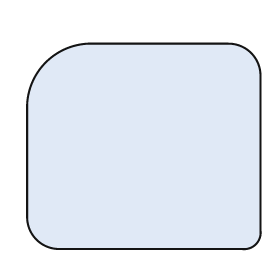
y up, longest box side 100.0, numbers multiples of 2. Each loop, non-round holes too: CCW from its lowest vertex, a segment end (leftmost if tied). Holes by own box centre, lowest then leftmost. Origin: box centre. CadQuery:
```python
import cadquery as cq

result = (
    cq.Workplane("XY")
    .moveTo(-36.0, -44.0)
    .lineTo(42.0, -44.0)
    .threePointArc((48.0, -42.0), (50.0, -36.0))
    .lineTo(50.0, 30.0)
    .threePointArc((46.0, 40.0), (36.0, 44.0))
    .lineTo(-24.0, 44.0)
    .threePointArc((-42.0, 36.0), (-50.0, 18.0))
    .lineTo(-50.0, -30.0)
    .threePointArc((-46.0, -40.0), (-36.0, -44.0))
    .close()
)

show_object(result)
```